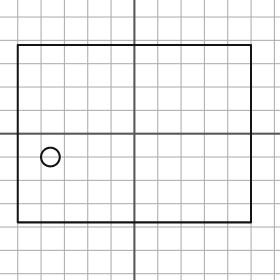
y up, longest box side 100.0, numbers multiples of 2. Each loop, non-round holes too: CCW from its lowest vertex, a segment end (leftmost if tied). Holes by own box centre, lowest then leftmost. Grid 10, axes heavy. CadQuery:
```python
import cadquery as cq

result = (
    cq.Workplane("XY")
    .moveTo(-50.0, -38.0)
    .lineTo(50.0, -38.0)
    .lineTo(50.0, 38.0)
    .lineTo(-50.0, 38.0)
    .close()
    .moveTo(-36.0, -10.0)
    .circle(4.0)
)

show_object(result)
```